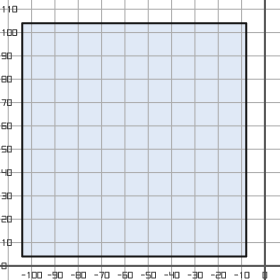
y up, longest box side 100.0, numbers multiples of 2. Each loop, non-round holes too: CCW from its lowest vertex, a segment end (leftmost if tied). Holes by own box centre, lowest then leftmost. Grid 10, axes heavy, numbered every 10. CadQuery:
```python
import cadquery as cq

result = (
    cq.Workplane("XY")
    .moveTo(-104.0, 4.0)
    .lineTo(-8.0, 4.0)
    .lineTo(-8.0, 104.0)
    .lineTo(-104.0, 104.0)
    .close()
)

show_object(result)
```